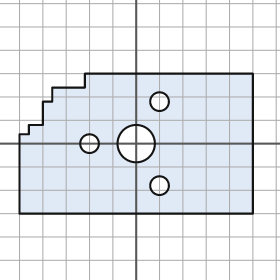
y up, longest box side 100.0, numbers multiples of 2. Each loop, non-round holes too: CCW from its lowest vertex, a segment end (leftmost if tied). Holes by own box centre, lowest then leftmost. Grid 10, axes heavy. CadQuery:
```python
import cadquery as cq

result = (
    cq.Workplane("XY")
    .moveTo(-50.0, -30.0)
    .lineTo(50.0, -30.0)
    .lineTo(50.0, 30.0)
    .lineTo(-22.0, 30.0)
    .lineTo(-22.0, 24.0)
    .lineTo(-36.0, 24.0)
    .lineTo(-36.0, 18.0)
    .lineTo(-40.0, 18.0)
    .lineTo(-40.0, 8.0)
    .lineTo(-46.0, 8.0)
    .lineTo(-46.0, 4.0)
    .lineTo(-50.0, 4.0)
    .close()
    .moveTo(10.0, -18.0)
    .circle(4.0)
    .moveTo(-20.0, 0.0)
    .circle(4.0)
    .moveTo(0.0, 0.0)
    .circle(8.0)
    .moveTo(10.0, 18.0)
    .circle(4.0)
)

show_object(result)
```